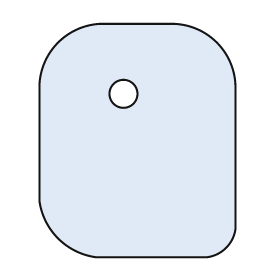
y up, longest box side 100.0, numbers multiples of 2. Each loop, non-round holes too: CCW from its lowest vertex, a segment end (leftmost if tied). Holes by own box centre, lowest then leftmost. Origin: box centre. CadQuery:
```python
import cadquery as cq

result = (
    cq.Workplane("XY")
    .moveTo(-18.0, -50.0)
    .lineTo(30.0, -50.0)
    .threePointArc((38.0, -46.0), (42.0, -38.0))
    .lineTo(42.0, 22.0)
    .threePointArc((34.0, 42.0), (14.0, 50.0))
    .lineTo(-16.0, 50.0)
    .threePointArc((-34.0, 42.0), (-42.0, 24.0))
    .lineTo(-42.0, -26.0)
    .threePointArc((-34.0, -42.0), (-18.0, -50.0))
    .close()
    .moveTo(-6.0, 20.0)
    .circle(6.0)
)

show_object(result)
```